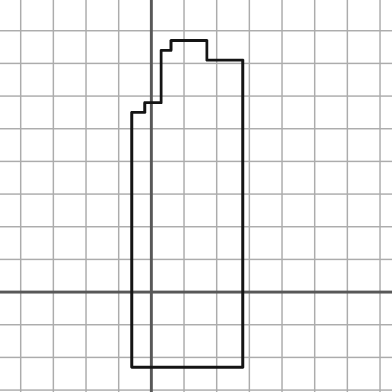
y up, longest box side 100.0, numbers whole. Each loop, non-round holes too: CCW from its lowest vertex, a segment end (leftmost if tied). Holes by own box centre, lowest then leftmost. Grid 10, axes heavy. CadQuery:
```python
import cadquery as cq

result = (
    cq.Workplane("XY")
    .moveTo(-6.0, -23.0)
    .lineTo(28.0, -23.0)
    .lineTo(28.0, 71.0)
    .lineTo(17.0, 71.0)
    .lineTo(17.0, 77.0)
    .lineTo(6.0, 77.0)
    .lineTo(6.0, 74.0)
    .lineTo(3.0, 74.0)
    .lineTo(3.0, 58.0)
    .lineTo(-2.0, 58.0)
    .lineTo(-2.0, 55.0)
    .lineTo(-6.0, 55.0)
    .close()
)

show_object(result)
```